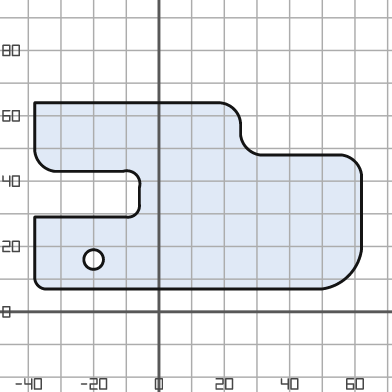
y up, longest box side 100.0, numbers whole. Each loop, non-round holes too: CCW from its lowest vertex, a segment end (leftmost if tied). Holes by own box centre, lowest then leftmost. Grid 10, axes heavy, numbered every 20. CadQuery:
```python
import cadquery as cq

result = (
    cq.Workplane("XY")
    .moveTo(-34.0, 7.0)
    .lineTo(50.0, 7.0)
    .threePointArc((58.0, 11.0), (62.0, 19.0))
    .lineTo(62.0, 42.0)
    .threePointArc((60.0, 46.0), (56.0, 48.0))
    .lineTo(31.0, 48.0)
    .threePointArc((27.0, 50.0), (25.0, 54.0))
    .lineTo(25.0, 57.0)
    .threePointArc((23.0, 62.0), (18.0, 64.0))
    .lineTo(-38.0, 64.0)
    .lineTo(-38.0, 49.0)
    .threePointArc((-36.0, 45.0), (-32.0, 43.0))
    .lineTo(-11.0, 43.0)
    .threePointArc((-7.0, 42.0), (-6.0, 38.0))
    .lineTo(-6.0, 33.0)
    .threePointArc((-7.0, 30.0), (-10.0, 29.0))
    .lineTo(-38.0, 29.0)
    .lineTo(-38.0, 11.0)
    .threePointArc((-37.0, 8.0), (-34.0, 7.0))
    .close()
    .moveTo(-20.0, 16.0)
    .circle(3.0)
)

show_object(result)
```